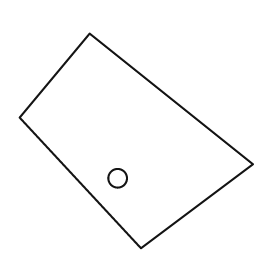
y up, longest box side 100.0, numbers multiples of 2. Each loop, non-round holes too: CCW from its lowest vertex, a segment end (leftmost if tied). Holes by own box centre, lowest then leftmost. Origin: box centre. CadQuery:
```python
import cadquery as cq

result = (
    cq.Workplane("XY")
    .moveTo(2.0, -46.0)
    .lineTo(50.0, -10.0)
    .lineTo(-20.0, 46.0)
    .lineTo(-50.0, 10.0)
    .close()
    .moveTo(-8.0, -16.0)
    .circle(4.0)
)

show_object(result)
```